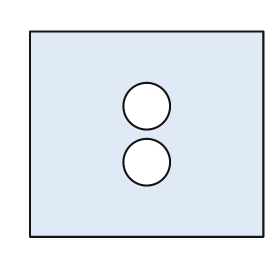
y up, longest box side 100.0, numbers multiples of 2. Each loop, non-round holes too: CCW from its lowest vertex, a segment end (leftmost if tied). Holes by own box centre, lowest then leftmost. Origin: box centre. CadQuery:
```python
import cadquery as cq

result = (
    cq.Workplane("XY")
    .moveTo(-50.0, -44.0)
    .lineTo(50.0, -44.0)
    .lineTo(50.0, 44.0)
    .lineTo(-50.0, 44.0)
    .close()
    .moveTo(0.0, -12.0)
    .circle(10.0)
    .moveTo(0.0, 12.0)
    .circle(10.0)
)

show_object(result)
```